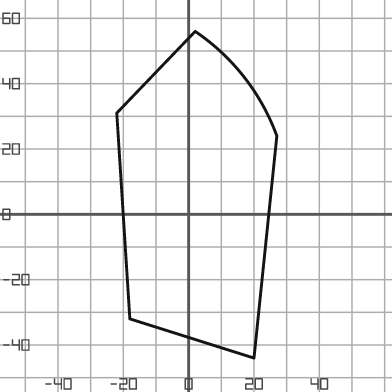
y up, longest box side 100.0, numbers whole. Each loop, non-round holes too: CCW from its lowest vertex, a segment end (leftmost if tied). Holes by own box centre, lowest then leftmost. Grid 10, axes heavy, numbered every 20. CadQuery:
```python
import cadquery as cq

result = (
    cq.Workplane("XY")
    .moveTo(20.0, -44.0)
    .lineTo(27.0, 24.0)
    .threePointArc((17.0, 42.0), (2.0, 56.0))
    .lineTo(-22.0, 31.0)
    .lineTo(-18.0, -32.0)
    .close()
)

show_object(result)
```